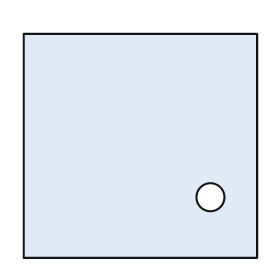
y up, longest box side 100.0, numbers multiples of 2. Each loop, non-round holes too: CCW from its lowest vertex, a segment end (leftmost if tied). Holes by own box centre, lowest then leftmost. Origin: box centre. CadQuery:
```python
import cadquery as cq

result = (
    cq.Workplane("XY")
    .moveTo(-50.0, -48.0)
    .lineTo(50.0, -48.0)
    .lineTo(50.0, 48.0)
    .lineTo(-50.0, 48.0)
    .close()
    .moveTo(30.0, -22.0)
    .circle(6.0)
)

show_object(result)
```